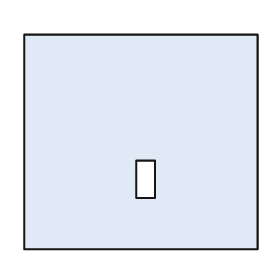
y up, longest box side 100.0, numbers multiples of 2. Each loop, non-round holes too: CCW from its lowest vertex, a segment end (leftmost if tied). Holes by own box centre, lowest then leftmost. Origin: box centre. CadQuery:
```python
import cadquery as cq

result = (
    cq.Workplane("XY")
    .moveTo(-50.0, -46.0)
    .lineTo(50.0, -46.0)
    .lineTo(50.0, 46.0)
    .lineTo(-50.0, 46.0)
    .close()
    .moveTo(-2.0, -24.0)
    .lineTo(6.0, -24.0)
    .lineTo(6.0, -8.0)
    .lineTo(-2.0, -8.0)
    .close()
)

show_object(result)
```